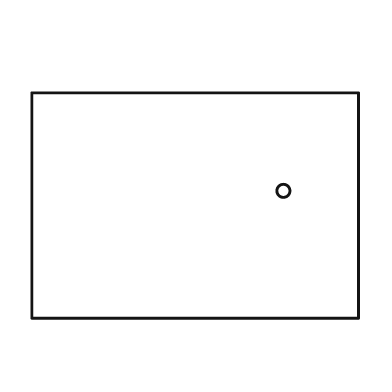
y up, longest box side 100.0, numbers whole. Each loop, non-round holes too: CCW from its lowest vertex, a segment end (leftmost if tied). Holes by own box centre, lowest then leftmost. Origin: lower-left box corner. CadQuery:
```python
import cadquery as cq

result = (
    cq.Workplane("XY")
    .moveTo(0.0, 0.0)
    .lineTo(100.0, 0.0)
    .lineTo(100.0, 69.0)
    .lineTo(0.0, 69.0)
    .close()
    .moveTo(77.0, 39.0)
    .circle(2.0)
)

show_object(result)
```